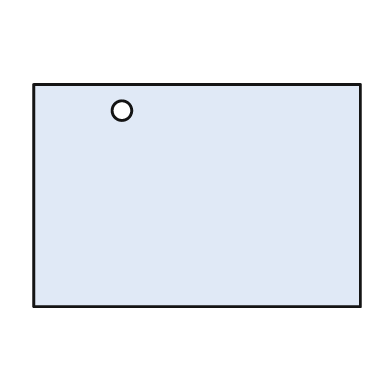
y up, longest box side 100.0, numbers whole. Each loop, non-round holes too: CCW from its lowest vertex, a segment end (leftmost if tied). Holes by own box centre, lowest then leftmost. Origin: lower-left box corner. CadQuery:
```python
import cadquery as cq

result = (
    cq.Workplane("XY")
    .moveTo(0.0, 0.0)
    .lineTo(100.0, 0.0)
    .lineTo(100.0, 68.0)
    .lineTo(0.0, 68.0)
    .close()
    .moveTo(27.0, 60.0)
    .circle(3.0)
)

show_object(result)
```